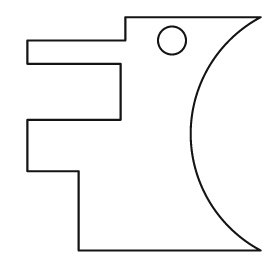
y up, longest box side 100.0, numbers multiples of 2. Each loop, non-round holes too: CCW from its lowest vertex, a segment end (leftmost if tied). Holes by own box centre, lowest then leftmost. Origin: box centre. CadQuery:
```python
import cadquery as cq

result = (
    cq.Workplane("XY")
    .moveTo(-28.0, -50.0)
    .lineTo(50.0, -50.0)
    .threePointArc((20.0, 0.0), (50.0, 50.0))
    .lineTo(-8.0, 50.0)
    .lineTo(-8.0, 40.0)
    .lineTo(-50.0, 40.0)
    .lineTo(-50.0, 30.0)
    .lineTo(-10.0, 30.0)
    .lineTo(-10.0, 6.0)
    .lineTo(-50.0, 6.0)
    .lineTo(-50.0, -16.0)
    .lineTo(-28.0, -16.0)
    .close()
    .moveTo(12.0, 40.0)
    .circle(6.0)
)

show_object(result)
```